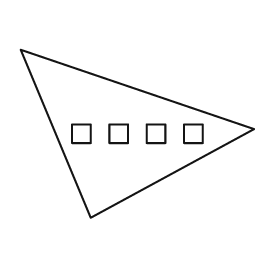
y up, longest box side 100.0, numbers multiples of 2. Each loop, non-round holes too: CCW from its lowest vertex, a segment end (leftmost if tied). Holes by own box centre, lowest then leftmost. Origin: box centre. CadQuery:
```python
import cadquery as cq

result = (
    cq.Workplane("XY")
    .moveTo(-20.0, -36.0)
    .lineTo(50.0, 2.0)
    .lineTo(-50.0, 36.0)
    .close()
    .moveTo(-28.0, -4.0)
    .lineTo(-20.0, -4.0)
    .lineTo(-20.0, 4.0)
    .lineTo(-28.0, 4.0)
    .close()
    .moveTo(-12.0, -4.0)
    .lineTo(-4.0, -4.0)
    .lineTo(-4.0, 4.0)
    .lineTo(-12.0, 4.0)
    .close()
    .moveTo(4.0, -4.0)
    .lineTo(12.0, -4.0)
    .lineTo(12.0, 4.0)
    .lineTo(4.0, 4.0)
    .close()
    .moveTo(20.0, -4.0)
    .lineTo(28.0, -4.0)
    .lineTo(28.0, 4.0)
    .lineTo(20.0, 4.0)
    .close()
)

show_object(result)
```